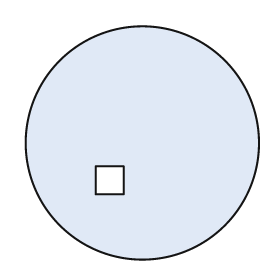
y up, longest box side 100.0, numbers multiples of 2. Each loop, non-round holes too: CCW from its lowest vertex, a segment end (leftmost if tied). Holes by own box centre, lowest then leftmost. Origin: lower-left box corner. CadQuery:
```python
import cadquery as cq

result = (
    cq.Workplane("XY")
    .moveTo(50.0, 50.0)
    .circle(50.0)
    .moveTo(30.0, 28.0)
    .lineTo(42.0, 28.0)
    .lineTo(42.0, 40.0)
    .lineTo(30.0, 40.0)
    .close()
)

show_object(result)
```